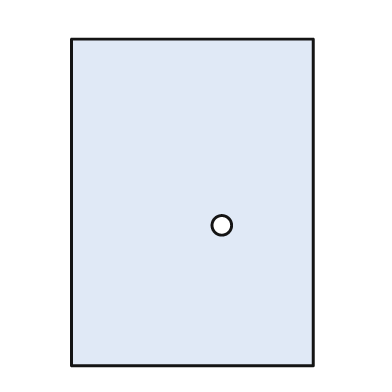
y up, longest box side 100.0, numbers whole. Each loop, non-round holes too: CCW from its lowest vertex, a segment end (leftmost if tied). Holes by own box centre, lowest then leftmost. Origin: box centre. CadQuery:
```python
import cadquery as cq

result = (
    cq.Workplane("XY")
    .moveTo(-37.0, -50.0)
    .lineTo(37.0, -50.0)
    .lineTo(37.0, 50.0)
    .lineTo(-37.0, 50.0)
    .close()
    .moveTo(9.0, -7.0)
    .circle(3.0)
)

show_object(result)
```